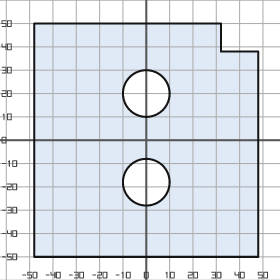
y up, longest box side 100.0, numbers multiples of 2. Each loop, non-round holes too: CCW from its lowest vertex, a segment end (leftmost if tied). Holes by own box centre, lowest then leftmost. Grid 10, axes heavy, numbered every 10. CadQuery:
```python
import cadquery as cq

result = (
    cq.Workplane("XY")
    .moveTo(-48.0, -50.0)
    .lineTo(48.0, -50.0)
    .lineTo(48.0, 38.0)
    .lineTo(32.0, 38.0)
    .lineTo(32.0, 50.0)
    .lineTo(-48.0, 50.0)
    .close()
    .moveTo(0.0, -18.0)
    .circle(10.0)
    .moveTo(0.0, 20.0)
    .circle(10.0)
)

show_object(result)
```